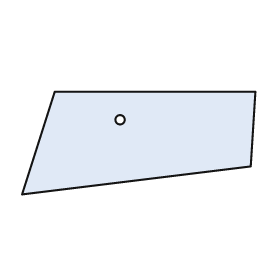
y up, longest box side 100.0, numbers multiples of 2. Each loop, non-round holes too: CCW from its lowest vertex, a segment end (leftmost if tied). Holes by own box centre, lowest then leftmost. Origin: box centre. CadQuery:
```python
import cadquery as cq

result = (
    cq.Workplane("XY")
    .moveTo(-50.0, -22.0)
    .lineTo(48.0, -10.0)
    .lineTo(50.0, 22.0)
    .lineTo(-36.0, 22.0)
    .close()
    .moveTo(-8.0, 10.0)
    .circle(2.0)
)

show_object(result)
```